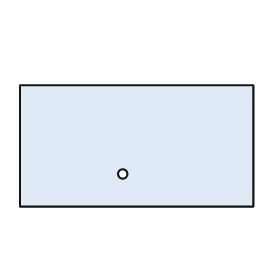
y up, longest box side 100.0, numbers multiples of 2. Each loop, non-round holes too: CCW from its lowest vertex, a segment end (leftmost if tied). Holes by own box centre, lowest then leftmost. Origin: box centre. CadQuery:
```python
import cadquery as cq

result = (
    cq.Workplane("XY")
    .moveTo(-50.0, -26.0)
    .lineTo(50.0, -26.0)
    .lineTo(50.0, 26.0)
    .lineTo(-50.0, 26.0)
    .close()
    .moveTo(-6.0, -12.0)
    .circle(2.0)
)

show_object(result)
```